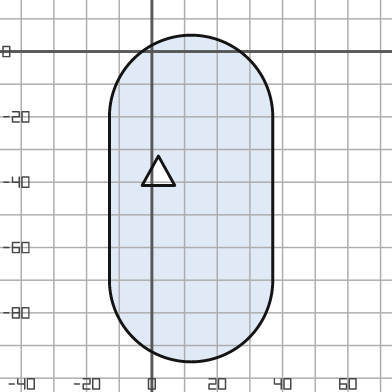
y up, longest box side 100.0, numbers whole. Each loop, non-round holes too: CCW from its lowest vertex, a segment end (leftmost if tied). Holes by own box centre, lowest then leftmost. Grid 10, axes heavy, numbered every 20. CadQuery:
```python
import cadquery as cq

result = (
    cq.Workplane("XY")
    .moveTo(-13.0, -70.0)
    .threePointArc((12.0, -95.0), (37.0, -70.0))
    .lineTo(37.0, -20.0)
    .threePointArc((12.0, 5.0), (-13.0, -20.0))
    .close()
    .moveTo(-3.0, -41.0)
    .lineTo(7.0, -41.0)
    .lineTo(2.0, -32.0)
    .close()
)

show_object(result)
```